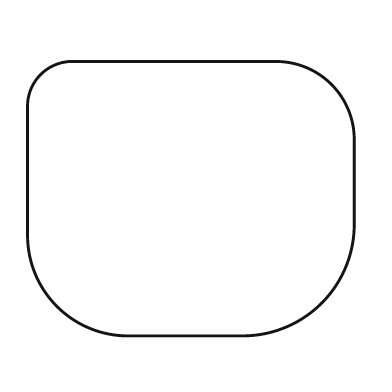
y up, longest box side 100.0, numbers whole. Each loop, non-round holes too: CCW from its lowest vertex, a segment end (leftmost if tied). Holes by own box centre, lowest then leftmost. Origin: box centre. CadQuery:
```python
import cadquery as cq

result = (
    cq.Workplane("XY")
    .moveTo(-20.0, -42.0)
    .lineTo(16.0, -42.0)
    .threePointArc((40.0, -32.0), (50.0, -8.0))
    .lineTo(50.0, 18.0)
    .threePointArc((43.0, 35.0), (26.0, 42.0))
    .lineTo(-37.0, 42.0)
    .threePointArc((-46.0, 38.0), (-50.0, 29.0))
    .lineTo(-50.0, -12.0)
    .threePointArc((-41.0, -33.0), (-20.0, -42.0))
    .close()
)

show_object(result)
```